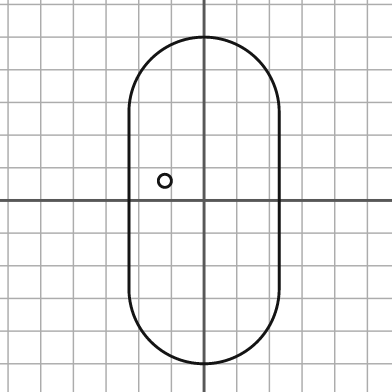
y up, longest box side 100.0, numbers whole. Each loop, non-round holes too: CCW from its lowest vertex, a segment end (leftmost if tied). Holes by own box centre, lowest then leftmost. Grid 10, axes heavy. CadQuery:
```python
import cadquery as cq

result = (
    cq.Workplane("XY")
    .moveTo(-23.0, -27.0)
    .threePointArc((0.0, -50.0), (23.0, -27.0))
    .lineTo(23.0, 27.0)
    .threePointArc((0.0, 50.0), (-23.0, 27.0))
    .close()
    .moveTo(-12.0, 6.0)
    .circle(2.0)
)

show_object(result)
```